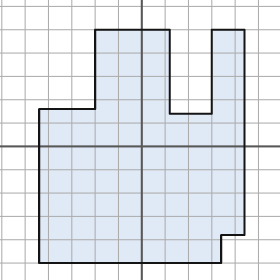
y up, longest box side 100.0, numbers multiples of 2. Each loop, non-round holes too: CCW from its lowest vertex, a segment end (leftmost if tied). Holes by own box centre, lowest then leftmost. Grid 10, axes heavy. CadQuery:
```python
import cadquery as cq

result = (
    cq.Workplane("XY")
    .moveTo(-44.0, -50.0)
    .lineTo(34.0, -50.0)
    .lineTo(34.0, -38.0)
    .lineTo(44.0, -38.0)
    .lineTo(44.0, 50.0)
    .lineTo(30.0, 50.0)
    .lineTo(30.0, 14.0)
    .lineTo(12.0, 14.0)
    .lineTo(12.0, 50.0)
    .lineTo(-20.0, 50.0)
    .lineTo(-20.0, 16.0)
    .lineTo(-44.0, 16.0)
    .close()
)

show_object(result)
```